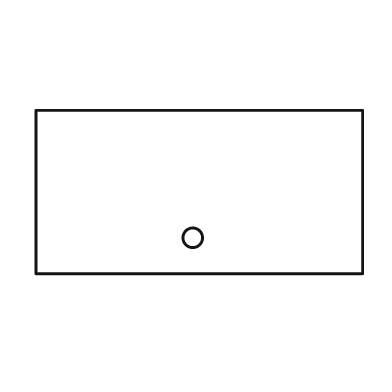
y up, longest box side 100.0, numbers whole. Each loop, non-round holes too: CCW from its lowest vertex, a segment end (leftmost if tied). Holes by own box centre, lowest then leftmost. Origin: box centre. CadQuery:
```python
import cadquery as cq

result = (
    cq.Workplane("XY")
    .moveTo(-50.0, -25.0)
    .lineTo(50.0, -25.0)
    .lineTo(50.0, 25.0)
    .lineTo(-50.0, 25.0)
    .close()
    .moveTo(-2.0, -14.0)
    .circle(3.0)
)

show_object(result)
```